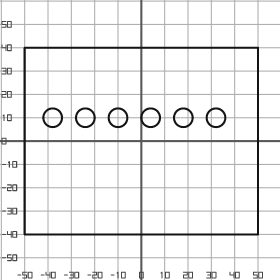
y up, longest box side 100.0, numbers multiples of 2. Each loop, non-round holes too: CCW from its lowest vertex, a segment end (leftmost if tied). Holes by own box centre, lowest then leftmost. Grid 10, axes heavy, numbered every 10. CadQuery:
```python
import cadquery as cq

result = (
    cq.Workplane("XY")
    .moveTo(-50.0, -40.0)
    .lineTo(50.0, -40.0)
    .lineTo(50.0, 40.0)
    .lineTo(-50.0, 40.0)
    .close()
    .moveTo(-38.0, 10.0)
    .circle(4.0)
    .moveTo(-24.0, 10.0)
    .circle(4.0)
    .moveTo(-10.0, 10.0)
    .circle(4.0)
    .moveTo(4.0, 10.0)
    .circle(4.0)
    .moveTo(18.0, 10.0)
    .circle(4.0)
    .moveTo(32.0, 10.0)
    .circle(4.0)
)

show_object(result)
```